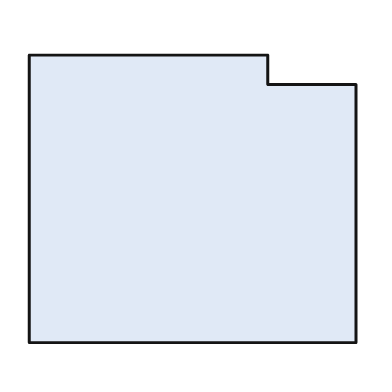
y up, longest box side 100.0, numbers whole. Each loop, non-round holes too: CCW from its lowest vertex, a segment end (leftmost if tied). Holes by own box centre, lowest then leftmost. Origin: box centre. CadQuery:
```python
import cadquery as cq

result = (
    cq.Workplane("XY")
    .moveTo(-50.0, -44.0)
    .lineTo(50.0, -44.0)
    .lineTo(50.0, 35.0)
    .lineTo(23.0, 35.0)
    .lineTo(23.0, 44.0)
    .lineTo(-50.0, 44.0)
    .close()
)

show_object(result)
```